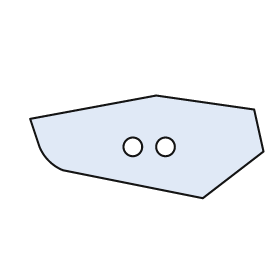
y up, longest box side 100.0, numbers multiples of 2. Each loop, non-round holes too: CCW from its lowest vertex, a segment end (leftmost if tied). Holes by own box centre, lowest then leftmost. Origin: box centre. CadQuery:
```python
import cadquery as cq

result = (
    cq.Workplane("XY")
    .moveTo(24.0, -22.0)
    .lineTo(50.0, -2.0)
    .lineTo(46.0, 16.0)
    .lineTo(4.0, 22.0)
    .lineTo(-50.0, 12.0)
    .lineTo(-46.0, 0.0)
    .threePointArc((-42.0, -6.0), (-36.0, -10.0))
    .close()
    .moveTo(-6.0, 0.0)
    .circle(4.0)
    .moveTo(8.0, 0.0)
    .circle(4.0)
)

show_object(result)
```